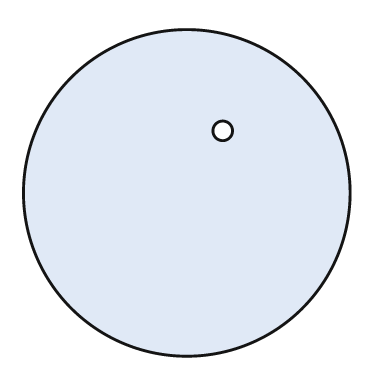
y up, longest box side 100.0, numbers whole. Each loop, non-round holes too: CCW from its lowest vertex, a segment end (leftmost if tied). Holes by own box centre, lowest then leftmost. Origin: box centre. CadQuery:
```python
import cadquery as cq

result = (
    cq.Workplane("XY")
    .moveTo(0.0, 0.0)
    .circle(50.0)
    .moveTo(11.0, 19.0)
    .circle(3.0)
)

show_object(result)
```